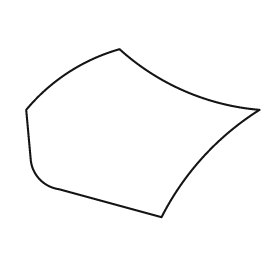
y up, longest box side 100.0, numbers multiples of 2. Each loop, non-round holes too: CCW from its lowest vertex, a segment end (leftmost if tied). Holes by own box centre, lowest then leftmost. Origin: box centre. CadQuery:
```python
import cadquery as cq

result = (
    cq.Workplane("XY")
    .moveTo(8.0, -36.0)
    .threePointArc((26.0, -10.0), (50.0, 10.0))
    .threePointArc((18.0, 18.0), (-10.0, 36.0))
    .threePointArc((-32.0, 26.0), (-50.0, 10.0))
    .lineTo(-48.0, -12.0)
    .threePointArc((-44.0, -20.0), (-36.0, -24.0))
    .close()
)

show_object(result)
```